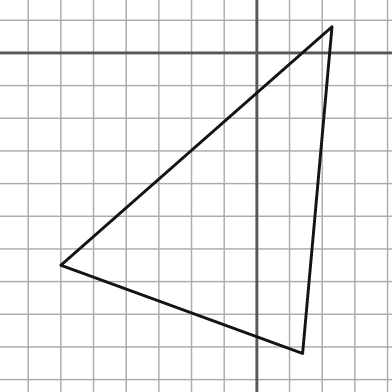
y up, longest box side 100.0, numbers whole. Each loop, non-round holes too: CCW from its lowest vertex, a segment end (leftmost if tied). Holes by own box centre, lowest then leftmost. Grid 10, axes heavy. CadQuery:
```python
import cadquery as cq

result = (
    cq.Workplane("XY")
    .moveTo(14.0, -92.0)
    .lineTo(23.0, 8.0)
    .lineTo(-60.0, -65.0)
    .close()
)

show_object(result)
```